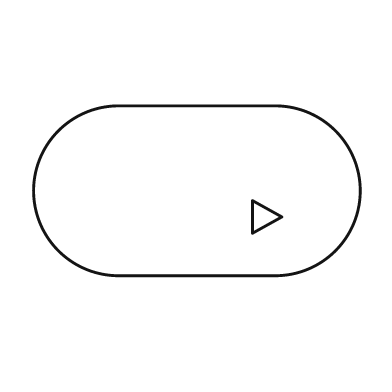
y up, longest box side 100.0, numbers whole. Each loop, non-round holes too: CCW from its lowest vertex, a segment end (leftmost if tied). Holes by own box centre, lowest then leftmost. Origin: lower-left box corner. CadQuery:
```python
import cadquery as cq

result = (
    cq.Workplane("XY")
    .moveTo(26.0, 0.0)
    .lineTo(74.0, 0.0)
    .threePointArc((100.0, 26.0), (74.0, 52.0))
    .lineTo(26.0, 52.0)
    .threePointArc((0.0, 26.0), (26.0, 0.0))
    .close()
    .moveTo(67.0, 13.0)
    .lineTo(76.0, 18.0)
    .lineTo(67.0, 23.0)
    .close()
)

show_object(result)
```